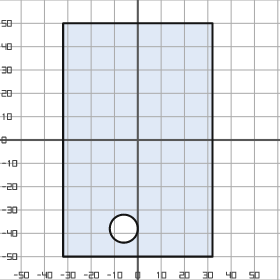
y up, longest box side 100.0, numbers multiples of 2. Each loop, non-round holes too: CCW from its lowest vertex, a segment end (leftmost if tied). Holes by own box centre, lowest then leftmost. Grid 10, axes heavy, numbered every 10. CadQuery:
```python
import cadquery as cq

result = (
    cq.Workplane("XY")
    .moveTo(-32.0, -50.0)
    .lineTo(32.0, -50.0)
    .lineTo(32.0, 50.0)
    .lineTo(-32.0, 50.0)
    .close()
    .moveTo(-6.0, -38.0)
    .circle(6.0)
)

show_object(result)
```